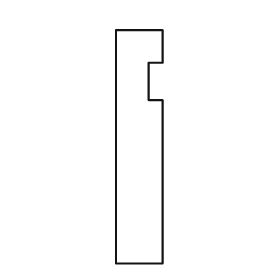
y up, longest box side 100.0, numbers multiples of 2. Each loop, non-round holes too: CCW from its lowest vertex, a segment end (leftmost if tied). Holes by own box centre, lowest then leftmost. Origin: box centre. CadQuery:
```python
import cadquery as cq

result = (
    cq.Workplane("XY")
    .moveTo(-10.0, -50.0)
    .lineTo(10.0, -50.0)
    .lineTo(10.0, 20.0)
    .lineTo(4.0, 20.0)
    .lineTo(4.0, 36.0)
    .lineTo(10.0, 36.0)
    .lineTo(10.0, 50.0)
    .lineTo(-10.0, 50.0)
    .close()
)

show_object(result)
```